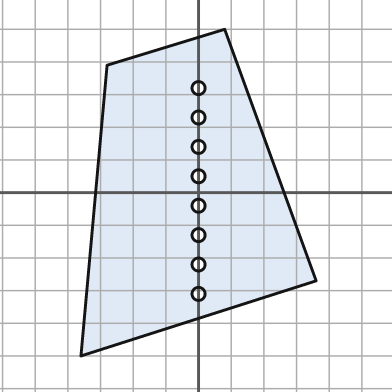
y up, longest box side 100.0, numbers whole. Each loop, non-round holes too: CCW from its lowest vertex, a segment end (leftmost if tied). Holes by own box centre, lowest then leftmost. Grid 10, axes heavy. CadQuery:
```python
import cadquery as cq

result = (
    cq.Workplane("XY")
    .moveTo(-36.0, -50.0)
    .lineTo(36.0, -27.0)
    .lineTo(8.0, 50.0)
    .lineTo(-28.0, 39.0)
    .close()
    .moveTo(0.0, -31.0)
    .circle(2.0)
    .moveTo(0.0, -22.0)
    .circle(2.0)
    .moveTo(0.0, -13.0)
    .circle(2.0)
    .moveTo(0.0, -4.0)
    .circle(2.0)
    .moveTo(0.0, 5.0)
    .circle(2.0)
    .moveTo(0.0, 14.0)
    .circle(2.0)
    .moveTo(0.0, 23.0)
    .circle(2.0)
    .moveTo(0.0, 32.0)
    .circle(2.0)
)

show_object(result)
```